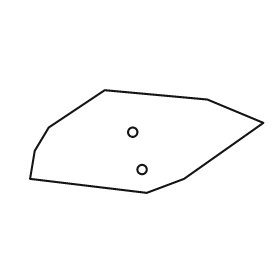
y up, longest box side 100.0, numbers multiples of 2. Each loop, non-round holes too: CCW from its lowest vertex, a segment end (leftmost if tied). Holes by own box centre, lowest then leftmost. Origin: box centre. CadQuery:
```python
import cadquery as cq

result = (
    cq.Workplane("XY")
    .moveTo(0.0, -22.0)
    .lineTo(16.0, -16.0)
    .lineTo(50.0, 8.0)
    .lineTo(26.0, 18.0)
    .lineTo(-18.0, 22.0)
    .lineTo(-42.0, 6.0)
    .lineTo(-48.0, -4.0)
    .lineTo(-50.0, -16.0)
    .close()
    .moveTo(-2.0, -12.0)
    .circle(2.0)
    .moveTo(-6.0, 4.0)
    .circle(2.0)
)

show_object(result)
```